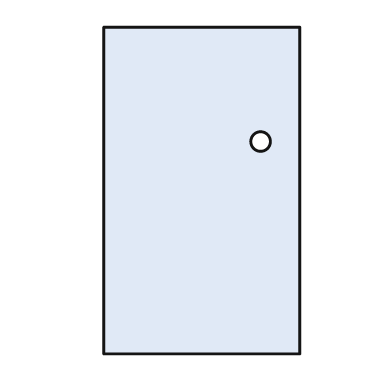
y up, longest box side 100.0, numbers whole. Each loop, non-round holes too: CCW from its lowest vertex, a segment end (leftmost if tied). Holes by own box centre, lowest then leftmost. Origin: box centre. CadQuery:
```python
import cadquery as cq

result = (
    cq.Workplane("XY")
    .moveTo(-30.0, -50.0)
    .lineTo(30.0, -50.0)
    .lineTo(30.0, 50.0)
    .lineTo(-30.0, 50.0)
    .close()
    .moveTo(18.0, 15.0)
    .circle(3.0)
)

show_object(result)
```